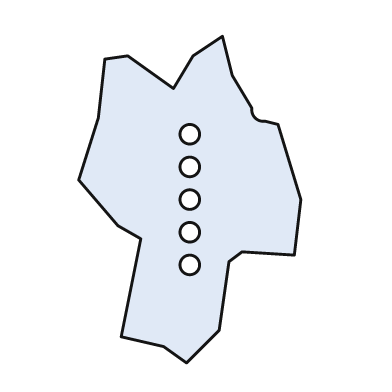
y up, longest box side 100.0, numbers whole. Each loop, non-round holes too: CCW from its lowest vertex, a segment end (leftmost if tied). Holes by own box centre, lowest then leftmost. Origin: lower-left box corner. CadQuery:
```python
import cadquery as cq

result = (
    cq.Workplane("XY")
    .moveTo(33.0, 0.0)
    .lineTo(43.0, 10.0)
    .lineTo(46.0, 31.0)
    .lineTo(50.0, 34.0)
    .lineTo(66.0, 33.0)
    .lineTo(68.0, 50.0)
    .lineTo(61.0, 73.0)
    .lineTo(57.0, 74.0)
    .threePointArc((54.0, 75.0), (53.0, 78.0))
    .lineTo(47.0, 88.0)
    .lineTo(44.0, 100.0)
    .lineTo(35.0, 94.0)
    .lineTo(29.0, 84.0)
    .lineTo(15.0, 94.0)
    .lineTo(8.0, 93.0)
    .lineTo(6.0, 75.0)
    .lineTo(0.0, 56.0)
    .lineTo(12.0, 42.0)
    .lineTo(19.0, 38.0)
    .lineTo(13.0, 8.0)
    .lineTo(26.0, 5.0)
    .close()
    .moveTo(34.0, 30.0)
    .circle(3.0)
    .moveTo(34.0, 40.0)
    .circle(3.0)
    .moveTo(34.0, 50.0)
    .circle(3.0)
    .moveTo(34.0, 60.0)
    .circle(3.0)
    .moveTo(34.0, 70.0)
    .circle(3.0)
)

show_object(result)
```